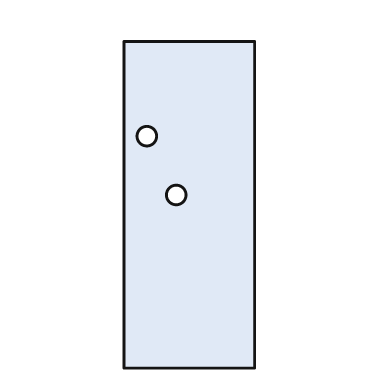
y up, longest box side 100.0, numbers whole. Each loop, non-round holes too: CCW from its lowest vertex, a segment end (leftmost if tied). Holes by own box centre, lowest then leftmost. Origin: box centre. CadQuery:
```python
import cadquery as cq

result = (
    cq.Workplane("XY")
    .moveTo(-20.0, -50.0)
    .lineTo(20.0, -50.0)
    .lineTo(20.0, 50.0)
    .lineTo(-20.0, 50.0)
    .close()
    .moveTo(-4.0, 3.0)
    .circle(3.0)
    .moveTo(-13.0, 21.0)
    .circle(3.0)
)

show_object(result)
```